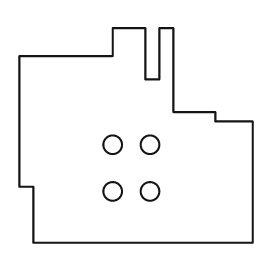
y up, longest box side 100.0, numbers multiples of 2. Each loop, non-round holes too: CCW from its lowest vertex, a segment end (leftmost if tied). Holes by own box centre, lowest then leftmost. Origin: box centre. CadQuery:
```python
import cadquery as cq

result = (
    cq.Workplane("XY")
    .moveTo(-44.0, -46.0)
    .lineTo(50.0, -46.0)
    .lineTo(50.0, 6.0)
    .lineTo(34.0, 6.0)
    .lineTo(34.0, 10.0)
    .lineTo(16.0, 10.0)
    .lineTo(16.0, 46.0)
    .lineTo(10.0, 46.0)
    .lineTo(10.0, 24.0)
    .lineTo(4.0, 24.0)
    .lineTo(4.0, 46.0)
    .lineTo(-10.0, 46.0)
    .lineTo(-10.0, 34.0)
    .lineTo(-50.0, 34.0)
    .lineTo(-50.0, -22.0)
    .lineTo(-44.0, -22.0)
    .close()
    .moveTo(-10.0, -24.0)
    .circle(4.0)
    .moveTo(6.0, -24.0)
    .circle(4.0)
    .moveTo(-10.0, -4.0)
    .circle(4.0)
    .moveTo(6.0, -4.0)
    .circle(4.0)
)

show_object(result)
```